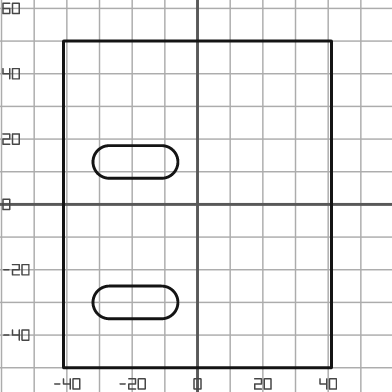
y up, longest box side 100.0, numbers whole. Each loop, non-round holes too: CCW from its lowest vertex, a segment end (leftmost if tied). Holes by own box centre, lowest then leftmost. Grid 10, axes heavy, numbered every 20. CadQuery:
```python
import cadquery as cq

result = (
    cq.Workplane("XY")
    .moveTo(-41.0, -50.0)
    .lineTo(41.0, -50.0)
    .lineTo(41.0, 50.0)
    .lineTo(-41.0, 50.0)
    .close()
    .moveTo(-27.0, -35.0)
    .lineTo(-11.0, -35.0)
    .threePointArc((-6.0, -30.0), (-11.0, -25.0))
    .lineTo(-27.0, -25.0)
    .threePointArc((-32.0, -30.0), (-27.0, -35.0))
    .close()
    .moveTo(-27.0, 8.0)
    .lineTo(-11.0, 8.0)
    .threePointArc((-6.0, 13.0), (-11.0, 18.0))
    .lineTo(-27.0, 18.0)
    .threePointArc((-32.0, 13.0), (-27.0, 8.0))
    .close()
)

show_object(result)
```